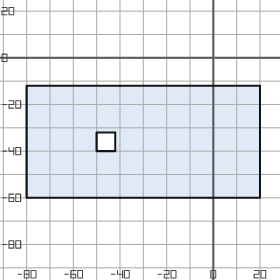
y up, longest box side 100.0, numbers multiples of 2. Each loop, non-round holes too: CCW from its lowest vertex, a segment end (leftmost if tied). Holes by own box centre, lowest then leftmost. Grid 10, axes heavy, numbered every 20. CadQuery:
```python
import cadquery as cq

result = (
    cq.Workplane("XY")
    .moveTo(-80.0, -60.0)
    .lineTo(20.0, -60.0)
    .lineTo(20.0, -12.0)
    .lineTo(-80.0, -12.0)
    .close()
    .moveTo(-50.0, -40.0)
    .lineTo(-42.0, -40.0)
    .lineTo(-42.0, -32.0)
    .lineTo(-50.0, -32.0)
    .close()
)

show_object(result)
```